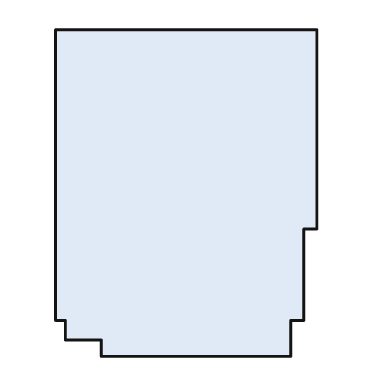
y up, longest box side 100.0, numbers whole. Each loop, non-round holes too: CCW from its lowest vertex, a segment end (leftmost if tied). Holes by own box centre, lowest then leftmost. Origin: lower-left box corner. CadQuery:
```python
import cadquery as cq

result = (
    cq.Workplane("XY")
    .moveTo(14.0, 0.0)
    .lineTo(72.0, 0.0)
    .lineTo(72.0, 11.0)
    .lineTo(76.0, 11.0)
    .lineTo(76.0, 39.0)
    .lineTo(80.0, 39.0)
    .lineTo(80.0, 100.0)
    .lineTo(0.0, 100.0)
    .lineTo(0.0, 11.0)
    .lineTo(3.0, 11.0)
    .lineTo(3.0, 5.0)
    .lineTo(14.0, 5.0)
    .close()
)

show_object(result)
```